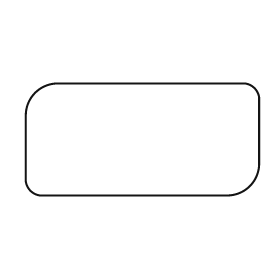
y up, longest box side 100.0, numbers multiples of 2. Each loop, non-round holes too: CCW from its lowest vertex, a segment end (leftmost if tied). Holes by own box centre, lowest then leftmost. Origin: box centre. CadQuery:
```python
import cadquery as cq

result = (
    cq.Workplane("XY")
    .moveTo(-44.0, -24.0)
    .lineTo(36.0, -24.0)
    .threePointArc((46.0, -20.0), (50.0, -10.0))
    .lineTo(50.0, 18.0)
    .threePointArc((48.0, 22.0), (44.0, 24.0))
    .lineTo(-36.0, 24.0)
    .threePointArc((-46.0, 20.0), (-50.0, 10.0))
    .lineTo(-50.0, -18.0)
    .threePointArc((-48.0, -22.0), (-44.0, -24.0))
    .close()
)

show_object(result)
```